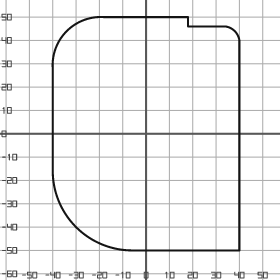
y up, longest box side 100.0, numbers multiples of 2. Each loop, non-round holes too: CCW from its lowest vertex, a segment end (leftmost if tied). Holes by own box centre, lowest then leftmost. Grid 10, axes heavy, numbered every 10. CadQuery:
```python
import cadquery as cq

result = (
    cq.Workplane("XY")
    .moveTo(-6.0, -50.0)
    .lineTo(40.0, -50.0)
    .lineTo(40.0, 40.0)
    .threePointArc((38.0, 44.0), (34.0, 46.0))
    .lineTo(18.0, 46.0)
    .lineTo(18.0, 50.0)
    .lineTo(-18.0, 50.0)
    .threePointArc((-34.0, 44.0), (-40.0, 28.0))
    .lineTo(-40.0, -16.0)
    .threePointArc((-30.0, -40.0), (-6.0, -50.0))
    .close()
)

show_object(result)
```